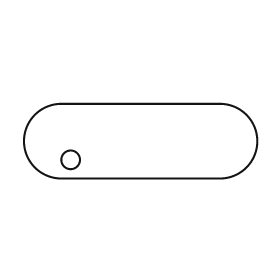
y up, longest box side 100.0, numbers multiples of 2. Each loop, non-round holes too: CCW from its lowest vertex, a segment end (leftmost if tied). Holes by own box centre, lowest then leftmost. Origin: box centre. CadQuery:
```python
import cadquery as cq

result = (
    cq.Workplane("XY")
    .moveTo(-34.0, -16.0)
    .lineTo(34.0, -16.0)
    .threePointArc((50.0, 0.0), (34.0, 16.0))
    .lineTo(-34.0, 16.0)
    .threePointArc((-50.0, 0.0), (-34.0, -16.0))
    .close()
    .moveTo(-30.0, -8.0)
    .circle(4.0)
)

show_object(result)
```